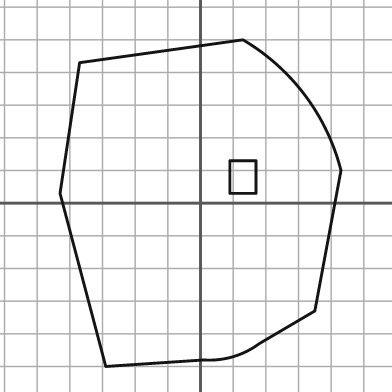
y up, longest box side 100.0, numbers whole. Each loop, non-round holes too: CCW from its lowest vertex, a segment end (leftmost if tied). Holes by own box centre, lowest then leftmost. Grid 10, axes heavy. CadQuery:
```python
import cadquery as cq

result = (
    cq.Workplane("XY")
    .moveTo(-29.0, -50.0)
    .lineTo(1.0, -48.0)
    .threePointArc((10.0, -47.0), (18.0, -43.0))
    .lineTo(35.0, -33.0)
    .lineTo(43.0, 10.0)
    .threePointArc((32.0, 33.0), (13.0, 50.0))
    .lineTo(-37.0, 43.0)
    .lineTo(-43.0, 3.0)
    .close()
    .moveTo(9.0, 3.0)
    .lineTo(17.0, 3.0)
    .lineTo(17.0, 13.0)
    .lineTo(9.0, 13.0)
    .close()
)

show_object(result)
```